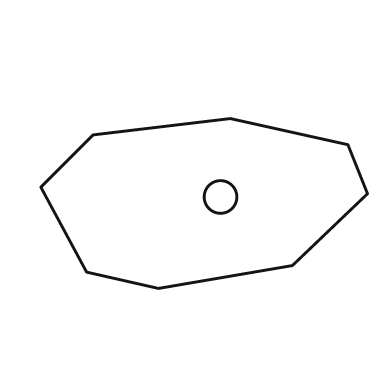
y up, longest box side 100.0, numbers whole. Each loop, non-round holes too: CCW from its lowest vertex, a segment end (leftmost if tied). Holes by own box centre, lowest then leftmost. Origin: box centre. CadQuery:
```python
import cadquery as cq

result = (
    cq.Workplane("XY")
    .moveTo(-14.0, -26.0)
    .lineTo(27.0, -19.0)
    .lineTo(50.0, 3.0)
    .lineTo(44.0, 18.0)
    .lineTo(8.0, 26.0)
    .lineTo(-34.0, 21.0)
    .lineTo(-50.0, 5.0)
    .lineTo(-36.0, -21.0)
    .close()
    .moveTo(5.0, 2.0)
    .circle(5.0)
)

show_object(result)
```